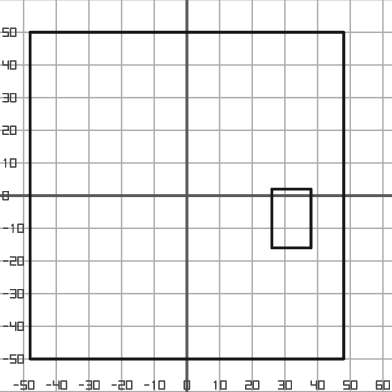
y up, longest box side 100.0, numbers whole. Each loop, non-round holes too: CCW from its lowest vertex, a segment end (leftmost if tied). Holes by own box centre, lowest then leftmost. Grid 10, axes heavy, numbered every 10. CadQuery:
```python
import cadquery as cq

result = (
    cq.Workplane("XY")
    .moveTo(-48.0, -50.0)
    .lineTo(48.0, -50.0)
    .lineTo(48.0, 50.0)
    .lineTo(-48.0, 50.0)
    .close()
    .moveTo(26.0, -16.0)
    .lineTo(38.0, -16.0)
    .lineTo(38.0, 2.0)
    .lineTo(26.0, 2.0)
    .close()
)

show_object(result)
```